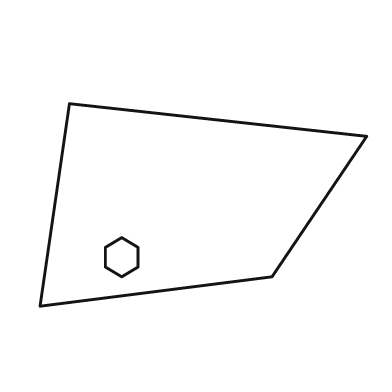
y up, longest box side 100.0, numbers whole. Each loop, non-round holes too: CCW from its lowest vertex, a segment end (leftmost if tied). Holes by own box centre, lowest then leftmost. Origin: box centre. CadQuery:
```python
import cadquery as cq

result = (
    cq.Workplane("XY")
    .moveTo(-50.0, -31.0)
    .lineTo(21.0, -22.0)
    .lineTo(50.0, 21.0)
    .lineTo(-41.0, 31.0)
    .close()
    .moveTo(-25.0, -22.0)
    .lineTo(-20.0, -19.0)
    .lineTo(-20.0, -13.0)
    .lineTo(-25.0, -10.0)
    .lineTo(-30.0, -13.0)
    .lineTo(-30.0, -19.0)
    .close()
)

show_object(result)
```